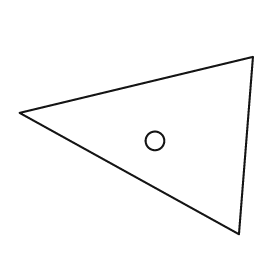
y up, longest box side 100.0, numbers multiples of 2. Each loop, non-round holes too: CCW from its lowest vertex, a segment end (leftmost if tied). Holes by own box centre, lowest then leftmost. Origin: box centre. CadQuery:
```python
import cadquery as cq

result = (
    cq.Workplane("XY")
    .moveTo(44.0, -38.0)
    .lineTo(50.0, 38.0)
    .lineTo(-50.0, 14.0)
    .close()
    .moveTo(8.0, 2.0)
    .circle(4.0)
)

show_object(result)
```